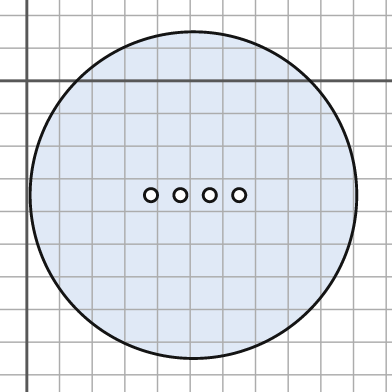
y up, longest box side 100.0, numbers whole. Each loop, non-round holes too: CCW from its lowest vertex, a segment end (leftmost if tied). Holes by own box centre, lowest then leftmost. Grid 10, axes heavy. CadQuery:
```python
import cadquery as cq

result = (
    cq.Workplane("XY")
    .moveTo(51.0, -35.0)
    .circle(50.0)
    .moveTo(38.0, -35.0)
    .circle(2.0)
    .moveTo(47.0, -35.0)
    .circle(2.0)
    .moveTo(56.0, -35.0)
    .circle(2.0)
    .moveTo(65.0, -35.0)
    .circle(2.0)
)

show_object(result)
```